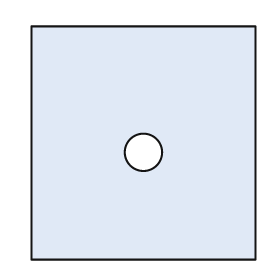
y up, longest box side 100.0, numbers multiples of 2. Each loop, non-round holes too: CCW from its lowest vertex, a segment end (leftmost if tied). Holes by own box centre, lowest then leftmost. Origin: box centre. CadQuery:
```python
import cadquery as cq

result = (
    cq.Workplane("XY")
    .moveTo(-48.0, -50.0)
    .lineTo(48.0, -50.0)
    .lineTo(48.0, 50.0)
    .lineTo(-48.0, 50.0)
    .close()
    .moveTo(0.0, -4.0)
    .circle(8.0)
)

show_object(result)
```